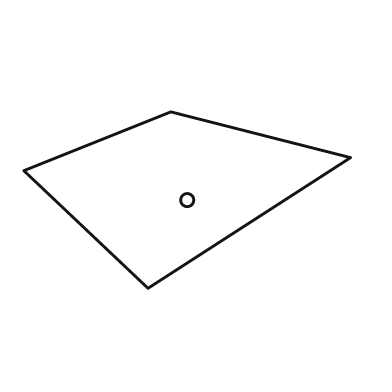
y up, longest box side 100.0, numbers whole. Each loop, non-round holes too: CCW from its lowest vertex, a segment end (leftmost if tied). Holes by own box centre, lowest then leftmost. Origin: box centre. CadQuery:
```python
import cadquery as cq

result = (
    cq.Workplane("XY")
    .moveTo(-12.0, -27.0)
    .lineTo(50.0, 13.0)
    .lineTo(-5.0, 27.0)
    .lineTo(-50.0, 9.0)
    .close()
    .moveTo(0.0, 0.0)
    .circle(2.0)
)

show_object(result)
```